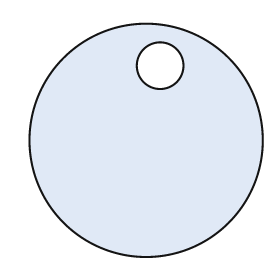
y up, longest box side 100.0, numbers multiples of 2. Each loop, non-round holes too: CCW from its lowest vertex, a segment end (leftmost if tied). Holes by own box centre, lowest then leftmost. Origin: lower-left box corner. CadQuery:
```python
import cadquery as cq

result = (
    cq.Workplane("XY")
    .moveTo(50.0, 50.0)
    .circle(50.0)
    .moveTo(56.0, 82.0)
    .circle(10.0)
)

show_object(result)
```